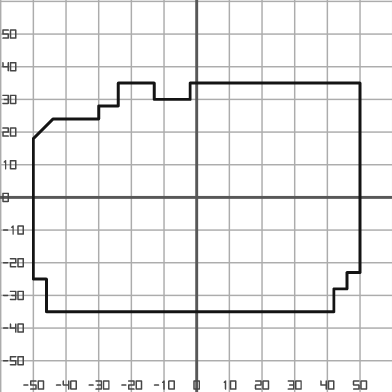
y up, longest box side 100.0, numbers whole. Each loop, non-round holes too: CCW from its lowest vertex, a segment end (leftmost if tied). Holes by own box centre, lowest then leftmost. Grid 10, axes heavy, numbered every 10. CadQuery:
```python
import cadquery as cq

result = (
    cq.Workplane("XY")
    .moveTo(-46.0, -35.0)
    .lineTo(42.0, -35.0)
    .lineTo(42.0, -28.0)
    .lineTo(46.0, -28.0)
    .lineTo(46.0, -23.0)
    .lineTo(50.0, -23.0)
    .lineTo(50.0, 35.0)
    .lineTo(-2.0, 35.0)
    .lineTo(-2.0, 30.0)
    .lineTo(-13.0, 30.0)
    .lineTo(-13.0, 35.0)
    .lineTo(-24.0, 35.0)
    .lineTo(-24.0, 28.0)
    .lineTo(-30.0, 28.0)
    .lineTo(-30.0, 24.0)
    .lineTo(-44.0, 24.0)
    .lineTo(-50.0, 18.0)
    .lineTo(-50.0, -25.0)
    .lineTo(-46.0, -25.0)
    .close()
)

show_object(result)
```